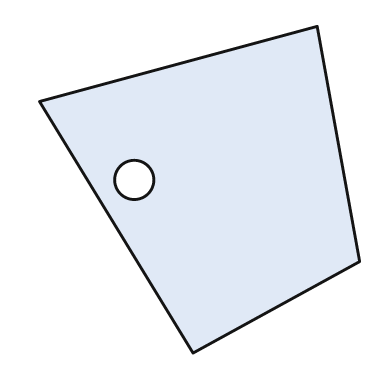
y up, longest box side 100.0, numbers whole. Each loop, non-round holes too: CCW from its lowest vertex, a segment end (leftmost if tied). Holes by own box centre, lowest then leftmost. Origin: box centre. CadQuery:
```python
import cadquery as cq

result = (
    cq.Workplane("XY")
    .moveTo(-2.0, -50.0)
    .lineTo(49.0, -22.0)
    .lineTo(36.0, 50.0)
    .lineTo(-49.0, 27.0)
    .close()
    .moveTo(-20.0, 3.0)
    .circle(6.0)
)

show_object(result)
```